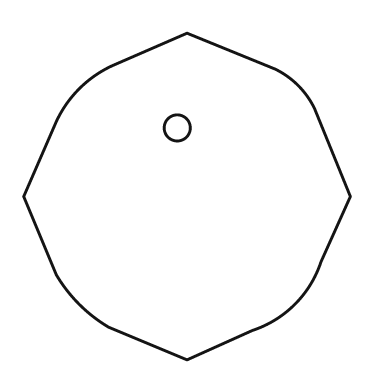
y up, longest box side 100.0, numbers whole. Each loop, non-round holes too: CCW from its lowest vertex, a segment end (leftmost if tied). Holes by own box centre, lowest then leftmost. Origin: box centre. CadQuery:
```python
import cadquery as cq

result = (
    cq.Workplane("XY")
    .moveTo(0.0, -50.0)
    .lineTo(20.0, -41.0)
    .threePointArc((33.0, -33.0), (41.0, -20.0))
    .lineTo(50.0, 0.0)
    .lineTo(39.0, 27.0)
    .threePointArc((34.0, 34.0), (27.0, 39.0))
    .lineTo(0.0, 50.0)
    .lineTo(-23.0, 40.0)
    .threePointArc((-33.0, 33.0), (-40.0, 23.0))
    .lineTo(-50.0, 0.0)
    .lineTo(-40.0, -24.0)
    .threePointArc((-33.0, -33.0), (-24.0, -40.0))
    .close()
    .moveTo(-3.0, 21.0)
    .circle(4.0)
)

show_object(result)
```